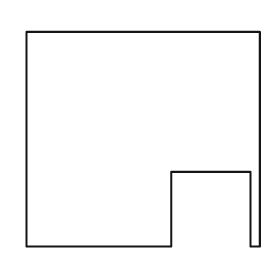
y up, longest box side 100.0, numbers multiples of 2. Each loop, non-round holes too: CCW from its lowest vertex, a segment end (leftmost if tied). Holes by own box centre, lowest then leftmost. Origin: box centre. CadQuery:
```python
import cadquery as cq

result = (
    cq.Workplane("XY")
    .moveTo(-50.0, -46.0)
    .lineTo(12.0, -46.0)
    .lineTo(12.0, -14.0)
    .lineTo(46.0, -14.0)
    .lineTo(46.0, -46.0)
    .lineTo(50.0, -46.0)
    .lineTo(50.0, 46.0)
    .lineTo(-50.0, 46.0)
    .close()
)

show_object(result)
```